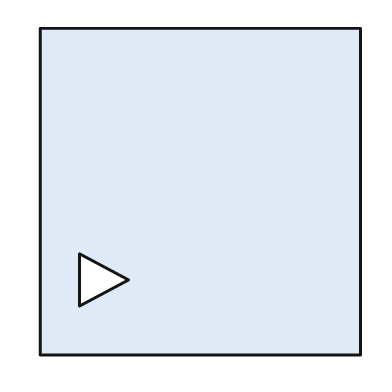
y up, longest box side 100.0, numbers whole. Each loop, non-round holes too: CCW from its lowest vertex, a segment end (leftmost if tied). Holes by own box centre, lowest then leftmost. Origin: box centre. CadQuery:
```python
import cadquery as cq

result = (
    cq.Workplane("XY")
    .moveTo(-49.0, -50.0)
    .lineTo(49.0, -50.0)
    .lineTo(49.0, 50.0)
    .lineTo(-49.0, 50.0)
    .close()
    .moveTo(-37.0, -35.0)
    .lineTo(-22.0, -27.0)
    .lineTo(-37.0, -19.0)
    .close()
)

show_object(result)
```